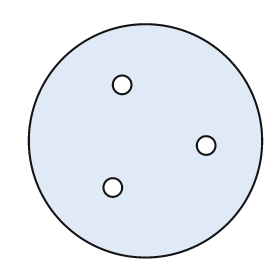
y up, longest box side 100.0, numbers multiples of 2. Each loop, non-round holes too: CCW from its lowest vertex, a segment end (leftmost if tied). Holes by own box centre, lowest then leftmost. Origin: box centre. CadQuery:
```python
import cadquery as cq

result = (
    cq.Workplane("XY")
    .moveTo(0.0, 0.0)
    .circle(50.0)
    .moveTo(-14.0, -20.0)
    .circle(4.0)
    .moveTo(26.0, -2.0)
    .circle(4.0)
    .moveTo(-10.0, 24.0)
    .circle(4.0)
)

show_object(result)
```